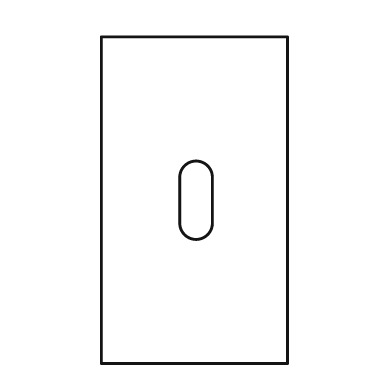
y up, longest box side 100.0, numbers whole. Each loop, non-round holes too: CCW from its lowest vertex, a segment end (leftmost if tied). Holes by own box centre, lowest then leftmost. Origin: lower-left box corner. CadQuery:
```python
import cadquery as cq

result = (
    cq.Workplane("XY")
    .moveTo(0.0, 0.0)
    .lineTo(57.0, 0.0)
    .lineTo(57.0, 100.0)
    .lineTo(0.0, 100.0)
    .close()
    .moveTo(24.0, 43.0)
    .threePointArc((29.0, 38.0), (34.0, 43.0))
    .lineTo(34.0, 57.0)
    .threePointArc((29.0, 62.0), (24.0, 57.0))
    .close()
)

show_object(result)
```